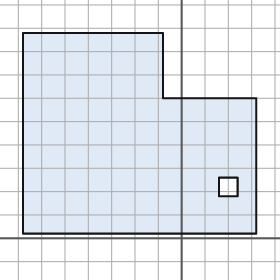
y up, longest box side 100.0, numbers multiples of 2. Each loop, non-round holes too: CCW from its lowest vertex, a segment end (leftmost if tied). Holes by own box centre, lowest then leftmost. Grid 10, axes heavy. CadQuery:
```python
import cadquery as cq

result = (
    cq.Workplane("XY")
    .moveTo(-68.0, 2.0)
    .lineTo(32.0, 2.0)
    .lineTo(32.0, 60.0)
    .lineTo(-8.0, 60.0)
    .lineTo(-8.0, 88.0)
    .lineTo(-68.0, 88.0)
    .close()
    .moveTo(16.0, 18.0)
    .lineTo(24.0, 18.0)
    .lineTo(24.0, 26.0)
    .lineTo(16.0, 26.0)
    .close()
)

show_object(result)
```